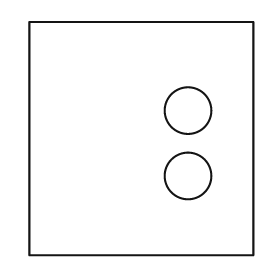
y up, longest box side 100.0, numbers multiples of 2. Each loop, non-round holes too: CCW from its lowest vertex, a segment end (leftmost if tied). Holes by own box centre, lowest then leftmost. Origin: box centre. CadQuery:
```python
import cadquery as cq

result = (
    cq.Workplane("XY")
    .moveTo(-48.0, -50.0)
    .lineTo(48.0, -50.0)
    .lineTo(48.0, 50.0)
    .lineTo(-48.0, 50.0)
    .close()
    .moveTo(20.0, -16.0)
    .circle(10.0)
    .moveTo(20.0, 12.0)
    .circle(10.0)
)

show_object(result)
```